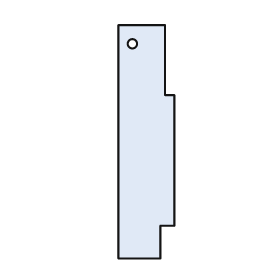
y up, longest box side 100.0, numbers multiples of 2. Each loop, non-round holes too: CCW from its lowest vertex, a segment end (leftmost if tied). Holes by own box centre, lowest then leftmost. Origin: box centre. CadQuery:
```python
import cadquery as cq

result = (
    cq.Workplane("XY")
    .moveTo(-12.0, -50.0)
    .lineTo(6.0, -50.0)
    .lineTo(6.0, -36.0)
    .lineTo(12.0, -36.0)
    .lineTo(12.0, 20.0)
    .lineTo(8.0, 20.0)
    .lineTo(8.0, 50.0)
    .lineTo(-12.0, 50.0)
    .close()
    .moveTo(-6.0, 42.0)
    .circle(2.0)
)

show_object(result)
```